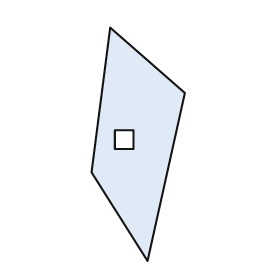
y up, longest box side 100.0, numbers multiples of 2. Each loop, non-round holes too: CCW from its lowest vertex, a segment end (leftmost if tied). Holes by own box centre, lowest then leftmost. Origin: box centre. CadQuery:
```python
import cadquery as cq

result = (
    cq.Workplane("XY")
    .moveTo(4.0, -50.0)
    .lineTo(20.0, 22.0)
    .lineTo(-12.0, 50.0)
    .lineTo(-20.0, -12.0)
    .close()
    .moveTo(-10.0, -2.0)
    .lineTo(-2.0, -2.0)
    .lineTo(-2.0, 6.0)
    .lineTo(-10.0, 6.0)
    .close()
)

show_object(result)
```